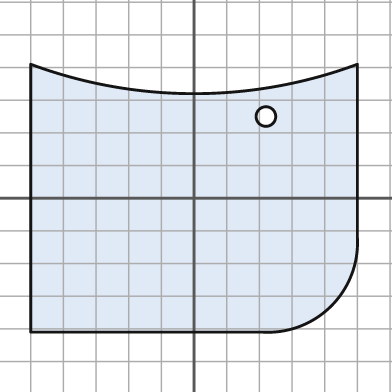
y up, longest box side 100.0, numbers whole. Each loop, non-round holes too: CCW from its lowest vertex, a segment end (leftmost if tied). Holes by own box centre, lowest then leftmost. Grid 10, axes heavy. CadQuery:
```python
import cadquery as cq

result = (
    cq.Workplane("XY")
    .moveTo(-50.0, -41.0)
    .lineTo(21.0, -41.0)
    .threePointArc((42.0, -33.0), (50.0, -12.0))
    .lineTo(50.0, 41.0)
    .threePointArc((0.0, 32.0), (-50.0, 41.0))
    .close()
    .moveTo(22.0, 25.0)
    .circle(3.0)
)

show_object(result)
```